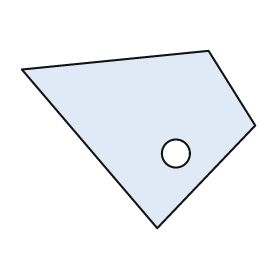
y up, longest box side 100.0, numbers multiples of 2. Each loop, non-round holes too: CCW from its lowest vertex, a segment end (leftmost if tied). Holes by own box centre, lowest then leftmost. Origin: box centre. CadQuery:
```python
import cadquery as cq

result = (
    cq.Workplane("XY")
    .moveTo(8.0, -38.0)
    .lineTo(50.0, 6.0)
    .lineTo(30.0, 38.0)
    .lineTo(-50.0, 30.0)
    .close()
    .moveTo(16.0, -6.0)
    .circle(6.0)
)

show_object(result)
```